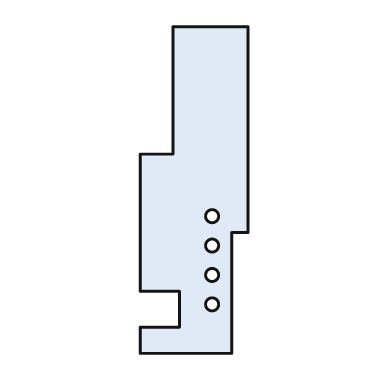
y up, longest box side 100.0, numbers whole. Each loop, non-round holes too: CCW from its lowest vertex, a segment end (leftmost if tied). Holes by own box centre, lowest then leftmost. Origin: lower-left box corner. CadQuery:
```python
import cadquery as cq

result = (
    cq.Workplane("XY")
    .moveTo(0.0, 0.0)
    .lineTo(28.0, 0.0)
    .lineTo(28.0, 37.0)
    .lineTo(33.0, 37.0)
    .lineTo(33.0, 100.0)
    .lineTo(10.0, 100.0)
    .lineTo(10.0, 61.0)
    .lineTo(0.0, 61.0)
    .lineTo(0.0, 19.0)
    .lineTo(12.0, 19.0)
    .lineTo(12.0, 8.0)
    .lineTo(0.0, 8.0)
    .close()
    .moveTo(22.0, 15.0)
    .circle(2.0)
    .moveTo(22.0, 24.0)
    .circle(2.0)
    .moveTo(22.0, 33.0)
    .circle(2.0)
    .moveTo(22.0, 42.0)
    .circle(2.0)
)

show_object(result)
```